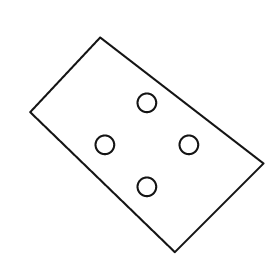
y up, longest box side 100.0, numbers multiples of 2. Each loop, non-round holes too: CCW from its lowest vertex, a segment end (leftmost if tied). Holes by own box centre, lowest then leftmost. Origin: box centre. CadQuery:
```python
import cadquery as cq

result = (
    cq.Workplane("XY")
    .moveTo(12.0, -46.0)
    .lineTo(50.0, -8.0)
    .lineTo(-20.0, 46.0)
    .lineTo(-50.0, 14.0)
    .close()
    .moveTo(0.0, -18.0)
    .circle(4.0)
    .moveTo(-18.0, 0.0)
    .circle(4.0)
    .moveTo(18.0, 0.0)
    .circle(4.0)
    .moveTo(0.0, 18.0)
    .circle(4.0)
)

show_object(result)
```